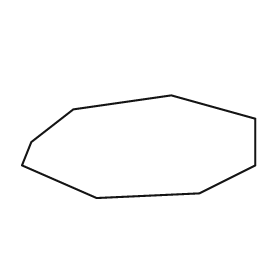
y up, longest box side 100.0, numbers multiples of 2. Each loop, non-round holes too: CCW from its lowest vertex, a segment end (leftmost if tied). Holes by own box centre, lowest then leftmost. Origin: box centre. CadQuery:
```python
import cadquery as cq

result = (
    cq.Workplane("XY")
    .moveTo(-18.0, -22.0)
    .lineTo(26.0, -20.0)
    .lineTo(50.0, -8.0)
    .lineTo(50.0, 12.0)
    .lineTo(14.0, 22.0)
    .lineTo(-28.0, 16.0)
    .lineTo(-46.0, 2.0)
    .lineTo(-50.0, -8.0)
    .close()
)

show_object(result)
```